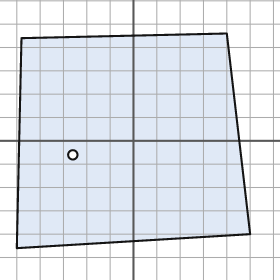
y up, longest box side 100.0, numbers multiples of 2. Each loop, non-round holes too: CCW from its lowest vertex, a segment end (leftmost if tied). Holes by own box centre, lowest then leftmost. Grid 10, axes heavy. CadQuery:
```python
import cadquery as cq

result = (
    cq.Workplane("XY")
    .moveTo(-50.0, -46.0)
    .lineTo(50.0, -40.0)
    .lineTo(40.0, 46.0)
    .lineTo(-48.0, 44.0)
    .close()
    .moveTo(-26.0, -6.0)
    .circle(2.0)
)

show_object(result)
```